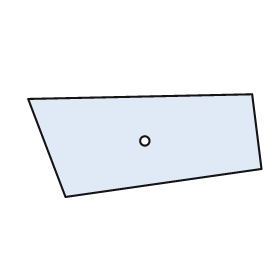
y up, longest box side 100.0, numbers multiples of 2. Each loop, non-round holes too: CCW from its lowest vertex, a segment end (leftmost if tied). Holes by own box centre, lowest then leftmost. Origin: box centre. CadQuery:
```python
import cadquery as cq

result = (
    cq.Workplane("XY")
    .moveTo(-34.0, -22.0)
    .lineTo(50.0, -10.0)
    .lineTo(46.0, 22.0)
    .lineTo(-50.0, 20.0)
    .close()
    .moveTo(0.0, 2.0)
    .circle(2.0)
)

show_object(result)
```